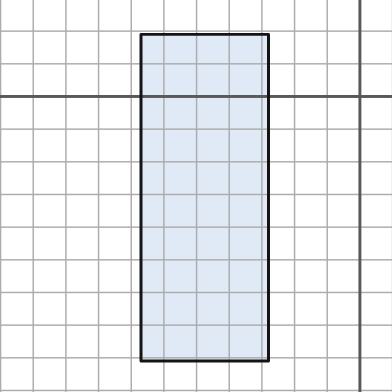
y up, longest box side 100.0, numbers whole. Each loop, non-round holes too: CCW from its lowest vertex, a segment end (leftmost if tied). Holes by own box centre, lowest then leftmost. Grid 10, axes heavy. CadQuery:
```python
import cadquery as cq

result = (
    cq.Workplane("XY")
    .moveTo(-67.0, -81.0)
    .lineTo(-28.0, -81.0)
    .lineTo(-28.0, 19.0)
    .lineTo(-67.0, 19.0)
    .close()
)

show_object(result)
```